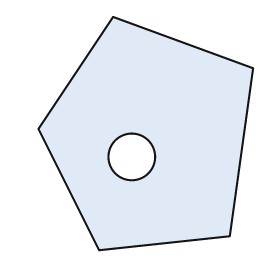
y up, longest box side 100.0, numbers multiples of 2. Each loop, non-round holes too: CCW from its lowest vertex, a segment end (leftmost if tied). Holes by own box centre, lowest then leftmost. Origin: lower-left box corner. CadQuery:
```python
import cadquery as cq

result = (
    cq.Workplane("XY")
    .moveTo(26.0, 0.0)
    .lineTo(82.0, 6.0)
    .lineTo(92.0, 78.0)
    .lineTo(32.0, 100.0)
    .lineTo(0.0, 52.0)
    .close()
    .moveTo(40.0, 40.0)
    .circle(10.0)
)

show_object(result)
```